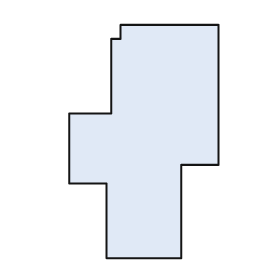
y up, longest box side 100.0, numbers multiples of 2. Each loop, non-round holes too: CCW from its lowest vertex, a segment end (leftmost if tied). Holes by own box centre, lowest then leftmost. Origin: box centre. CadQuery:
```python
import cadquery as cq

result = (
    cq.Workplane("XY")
    .moveTo(-16.0, -50.0)
    .lineTo(16.0, -50.0)
    .lineTo(16.0, -10.0)
    .lineTo(32.0, -10.0)
    .lineTo(32.0, 50.0)
    .lineTo(-10.0, 50.0)
    .lineTo(-10.0, 44.0)
    .lineTo(-14.0, 44.0)
    .lineTo(-14.0, 12.0)
    .lineTo(-32.0, 12.0)
    .lineTo(-32.0, -18.0)
    .lineTo(-16.0, -18.0)
    .close()
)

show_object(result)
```